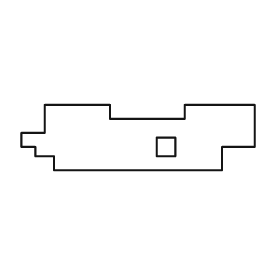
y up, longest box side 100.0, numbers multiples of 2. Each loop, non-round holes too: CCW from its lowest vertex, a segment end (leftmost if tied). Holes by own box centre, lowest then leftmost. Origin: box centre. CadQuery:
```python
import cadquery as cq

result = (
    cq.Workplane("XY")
    .moveTo(-36.0, -14.0)
    .lineTo(36.0, -14.0)
    .lineTo(36.0, -4.0)
    .lineTo(50.0, -4.0)
    .lineTo(50.0, 14.0)
    .lineTo(20.0, 14.0)
    .lineTo(20.0, 8.0)
    .lineTo(-12.0, 8.0)
    .lineTo(-12.0, 14.0)
    .lineTo(-40.0, 14.0)
    .lineTo(-40.0, 2.0)
    .lineTo(-50.0, 2.0)
    .lineTo(-50.0, -4.0)
    .lineTo(-44.0, -4.0)
    .lineTo(-44.0, -8.0)
    .lineTo(-36.0, -8.0)
    .close()
    .moveTo(8.0, -8.0)
    .lineTo(16.0, -8.0)
    .lineTo(16.0, 0.0)
    .lineTo(8.0, 0.0)
    .close()
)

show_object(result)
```